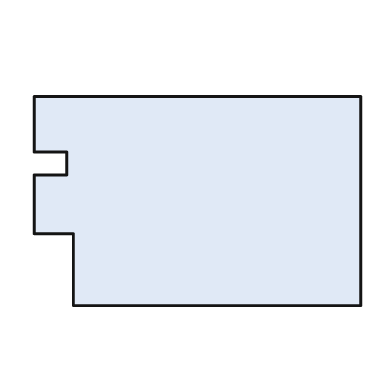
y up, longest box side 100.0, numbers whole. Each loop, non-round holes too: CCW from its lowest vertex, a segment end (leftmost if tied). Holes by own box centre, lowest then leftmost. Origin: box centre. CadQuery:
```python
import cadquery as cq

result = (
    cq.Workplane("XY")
    .moveTo(-38.0, -32.0)
    .lineTo(50.0, -32.0)
    .lineTo(50.0, 32.0)
    .lineTo(-50.0, 32.0)
    .lineTo(-50.0, 15.0)
    .lineTo(-40.0, 15.0)
    .lineTo(-40.0, 8.0)
    .lineTo(-50.0, 8.0)
    .lineTo(-50.0, -10.0)
    .lineTo(-38.0, -10.0)
    .close()
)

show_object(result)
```